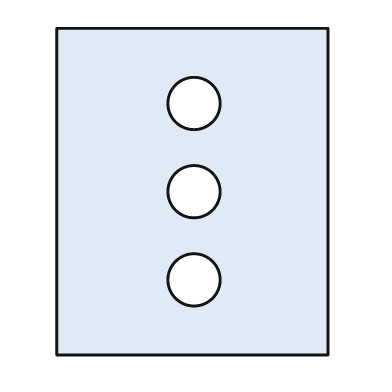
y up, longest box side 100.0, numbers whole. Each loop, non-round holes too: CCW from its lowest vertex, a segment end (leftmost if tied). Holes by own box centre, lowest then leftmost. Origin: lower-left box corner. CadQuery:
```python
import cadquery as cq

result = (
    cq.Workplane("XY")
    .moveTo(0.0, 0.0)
    .lineTo(83.0, 0.0)
    .lineTo(83.0, 100.0)
    .lineTo(0.0, 100.0)
    .close()
    .moveTo(42.0, 23.0)
    .circle(8.0)
    .moveTo(42.0, 50.0)
    .circle(8.0)
    .moveTo(42.0, 77.0)
    .circle(8.0)
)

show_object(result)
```